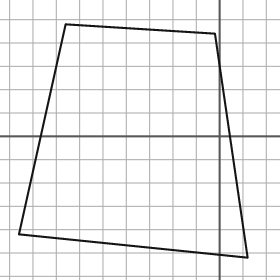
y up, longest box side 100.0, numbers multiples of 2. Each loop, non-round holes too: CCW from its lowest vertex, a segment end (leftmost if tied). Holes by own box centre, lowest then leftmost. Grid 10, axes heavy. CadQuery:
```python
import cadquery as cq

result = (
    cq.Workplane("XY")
    .moveTo(12.0, -52.0)
    .lineTo(-2.0, 44.0)
    .lineTo(-66.0, 48.0)
    .lineTo(-86.0, -42.0)
    .close()
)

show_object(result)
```